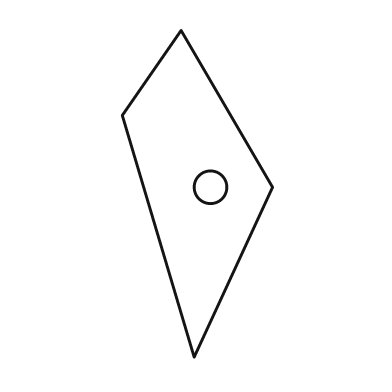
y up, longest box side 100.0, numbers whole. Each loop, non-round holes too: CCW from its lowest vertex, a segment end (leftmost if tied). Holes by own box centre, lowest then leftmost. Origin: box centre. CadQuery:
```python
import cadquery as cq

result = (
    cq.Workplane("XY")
    .moveTo(-1.0, -50.0)
    .lineTo(23.0, 2.0)
    .lineTo(-5.0, 50.0)
    .lineTo(-23.0, 24.0)
    .close()
    .moveTo(4.0, 2.0)
    .circle(5.0)
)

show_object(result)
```